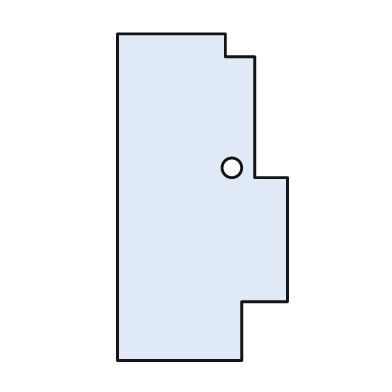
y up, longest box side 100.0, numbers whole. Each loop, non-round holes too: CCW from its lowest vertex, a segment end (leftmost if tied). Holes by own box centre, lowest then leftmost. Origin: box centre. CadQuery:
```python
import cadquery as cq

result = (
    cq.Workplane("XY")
    .moveTo(-26.0, -50.0)
    .lineTo(12.0, -50.0)
    .lineTo(12.0, -32.0)
    .lineTo(26.0, -32.0)
    .lineTo(26.0, 6.0)
    .lineTo(16.0, 6.0)
    .lineTo(16.0, 43.0)
    .lineTo(7.0, 43.0)
    .lineTo(7.0, 50.0)
    .lineTo(-26.0, 50.0)
    .close()
    .moveTo(9.0, 9.0)
    .circle(3.0)
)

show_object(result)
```